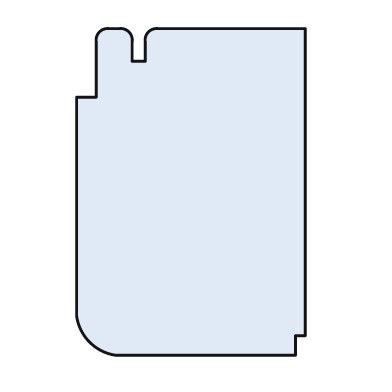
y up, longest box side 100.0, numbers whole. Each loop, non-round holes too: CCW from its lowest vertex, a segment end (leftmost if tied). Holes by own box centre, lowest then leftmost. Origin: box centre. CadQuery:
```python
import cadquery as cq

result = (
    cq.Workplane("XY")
    .moveTo(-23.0, -50.0)
    .lineTo(32.0, -50.0)
    .lineTo(32.0, -44.0)
    .lineTo(35.0, -44.0)
    .lineTo(35.0, 50.0)
    .lineTo(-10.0, 50.0)
    .threePointArc((-13.0, 49.0), (-14.0, 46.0))
    .lineTo(-14.0, 40.0)
    .lineTo(-18.0, 40.0)
    .lineTo(-18.0, 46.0)
    .threePointArc((-19.0, 49.0), (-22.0, 50.0))
    .lineTo(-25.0, 50.0)
    .threePointArc((-28.0, 49.0), (-29.0, 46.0))
    .lineTo(-29.0, 29.0)
    .lineTo(-35.0, 29.0)
    .lineTo(-35.0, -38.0)
    .threePointArc((-31.0, -46.0), (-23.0, -50.0))
    .close()
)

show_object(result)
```